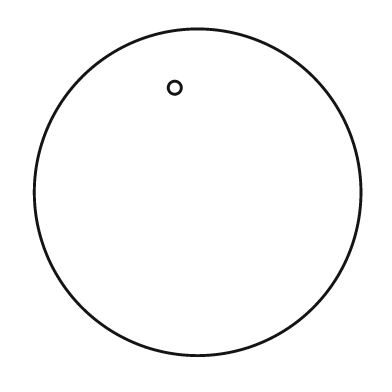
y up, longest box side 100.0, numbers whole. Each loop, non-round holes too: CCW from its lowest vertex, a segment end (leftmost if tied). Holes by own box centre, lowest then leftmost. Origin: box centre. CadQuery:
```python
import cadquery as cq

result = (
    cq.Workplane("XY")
    .moveTo(0.0, 0.0)
    .circle(50.0)
    .moveTo(-7.0, 32.0)
    .circle(2.0)
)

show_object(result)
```